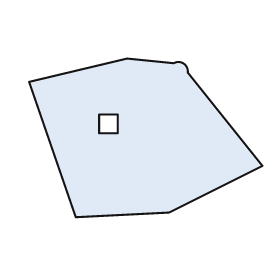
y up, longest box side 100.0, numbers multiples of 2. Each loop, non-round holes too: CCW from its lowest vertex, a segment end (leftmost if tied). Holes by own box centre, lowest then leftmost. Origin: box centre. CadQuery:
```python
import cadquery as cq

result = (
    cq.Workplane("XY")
    .moveTo(-30.0, -34.0)
    .lineTo(10.0, -32.0)
    .lineTo(50.0, -12.0)
    .lineTo(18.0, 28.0)
    .threePointArc((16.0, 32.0), (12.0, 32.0))
    .lineTo(-8.0, 34.0)
    .lineTo(-50.0, 24.0)
    .close()
    .moveTo(-20.0, 2.0)
    .lineTo(-12.0, 2.0)
    .lineTo(-12.0, 10.0)
    .lineTo(-20.0, 10.0)
    .close()
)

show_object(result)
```